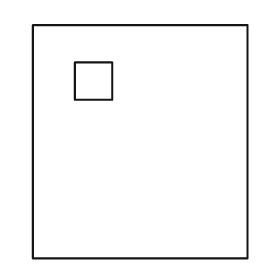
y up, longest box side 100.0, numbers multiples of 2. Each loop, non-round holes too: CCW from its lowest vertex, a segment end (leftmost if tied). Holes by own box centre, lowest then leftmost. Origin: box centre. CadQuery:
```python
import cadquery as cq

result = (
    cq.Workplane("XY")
    .moveTo(-46.0, -50.0)
    .lineTo(46.0, -50.0)
    .lineTo(46.0, 50.0)
    .lineTo(-46.0, 50.0)
    .close()
    .moveTo(-28.0, 18.0)
    .lineTo(-12.0, 18.0)
    .lineTo(-12.0, 34.0)
    .lineTo(-28.0, 34.0)
    .close()
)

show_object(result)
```